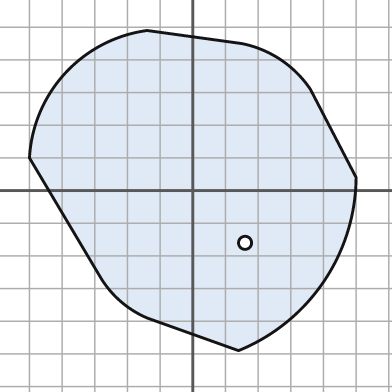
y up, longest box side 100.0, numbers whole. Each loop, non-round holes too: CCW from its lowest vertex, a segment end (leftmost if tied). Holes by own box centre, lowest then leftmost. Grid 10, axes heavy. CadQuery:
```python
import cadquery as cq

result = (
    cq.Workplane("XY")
    .moveTo(14.0, -49.0)
    .threePointArc((40.0, -28.0), (50.0, 4.0))
    .lineTo(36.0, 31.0)
    .threePointArc((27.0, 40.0), (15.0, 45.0))
    .lineTo(-14.0, 49.0)
    .threePointArc((-39.0, 36.0), (-50.0, 10.0))
    .lineTo(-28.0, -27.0)
    .threePointArc((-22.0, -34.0), (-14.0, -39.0))
    .close()
    .moveTo(16.0, -16.0)
    .circle(2.0)
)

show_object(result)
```